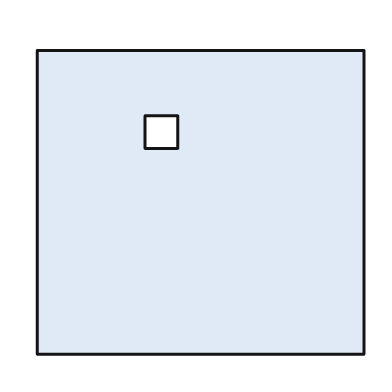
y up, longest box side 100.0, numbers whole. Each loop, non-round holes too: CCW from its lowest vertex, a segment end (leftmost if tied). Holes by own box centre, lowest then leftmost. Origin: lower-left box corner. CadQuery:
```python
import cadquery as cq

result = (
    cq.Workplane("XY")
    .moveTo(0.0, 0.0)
    .lineTo(100.0, 0.0)
    .lineTo(100.0, 93.0)
    .lineTo(0.0, 93.0)
    .close()
    .moveTo(33.0, 63.0)
    .lineTo(43.0, 63.0)
    .lineTo(43.0, 73.0)
    .lineTo(33.0, 73.0)
    .close()
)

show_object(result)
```